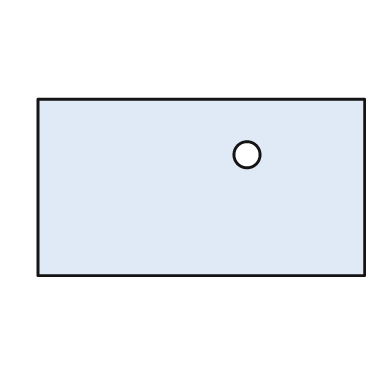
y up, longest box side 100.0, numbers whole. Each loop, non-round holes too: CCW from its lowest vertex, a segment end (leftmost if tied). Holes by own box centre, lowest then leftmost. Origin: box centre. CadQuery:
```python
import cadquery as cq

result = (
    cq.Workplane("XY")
    .moveTo(-50.0, -27.0)
    .lineTo(50.0, -27.0)
    .lineTo(50.0, 27.0)
    .lineTo(-50.0, 27.0)
    .close()
    .moveTo(14.0, 10.0)
    .circle(4.0)
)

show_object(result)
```